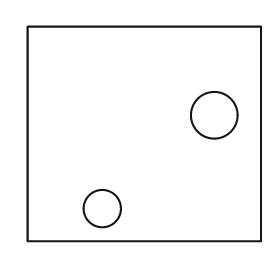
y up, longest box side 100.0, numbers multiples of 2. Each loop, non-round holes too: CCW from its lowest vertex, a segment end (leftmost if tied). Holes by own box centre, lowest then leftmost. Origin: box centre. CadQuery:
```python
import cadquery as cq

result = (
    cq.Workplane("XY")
    .moveTo(-50.0, -46.0)
    .lineTo(50.0, -46.0)
    .lineTo(50.0, 46.0)
    .lineTo(-50.0, 46.0)
    .close()
    .moveTo(-18.0, -32.0)
    .circle(8.0)
    .moveTo(30.0, 8.0)
    .circle(10.0)
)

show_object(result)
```